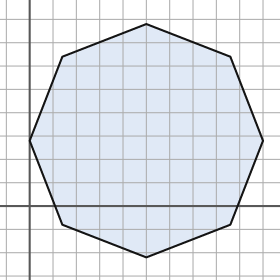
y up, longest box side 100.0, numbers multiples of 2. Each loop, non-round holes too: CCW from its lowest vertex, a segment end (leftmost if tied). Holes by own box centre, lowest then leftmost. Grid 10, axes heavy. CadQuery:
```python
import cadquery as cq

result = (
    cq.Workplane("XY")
    .moveTo(50.0, -22.0)
    .lineTo(86.0, -8.0)
    .lineTo(100.0, 28.0)
    .lineTo(86.0, 64.0)
    .lineTo(50.0, 78.0)
    .lineTo(14.0, 64.0)
    .lineTo(0.0, 28.0)
    .lineTo(14.0, -8.0)
    .close()
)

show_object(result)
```